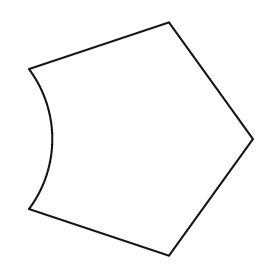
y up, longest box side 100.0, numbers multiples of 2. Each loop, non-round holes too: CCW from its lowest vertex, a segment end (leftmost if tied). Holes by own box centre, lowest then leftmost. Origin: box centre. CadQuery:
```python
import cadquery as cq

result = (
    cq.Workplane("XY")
    .moveTo(12.0, -50.0)
    .lineTo(48.0, 0.0)
    .lineTo(12.0, 50.0)
    .lineTo(-48.0, 30.0)
    .threePointArc((-38.0, 0.0), (-48.0, -30.0))
    .close()
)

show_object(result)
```